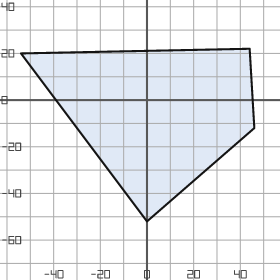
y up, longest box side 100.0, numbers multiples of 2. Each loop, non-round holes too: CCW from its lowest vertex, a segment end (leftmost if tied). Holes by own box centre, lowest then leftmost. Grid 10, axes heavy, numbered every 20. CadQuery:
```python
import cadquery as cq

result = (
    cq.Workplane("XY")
    .moveTo(0.0, -52.0)
    .lineTo(46.0, -12.0)
    .lineTo(44.0, 22.0)
    .lineTo(-54.0, 20.0)
    .close()
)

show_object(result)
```